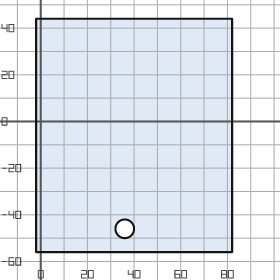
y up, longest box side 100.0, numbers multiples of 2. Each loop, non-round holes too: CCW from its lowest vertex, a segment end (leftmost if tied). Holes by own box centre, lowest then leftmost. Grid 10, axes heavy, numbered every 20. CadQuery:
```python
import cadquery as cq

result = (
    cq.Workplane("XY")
    .moveTo(-2.0, -56.0)
    .lineTo(82.0, -56.0)
    .lineTo(82.0, 44.0)
    .lineTo(-2.0, 44.0)
    .close()
    .moveTo(36.0, -46.0)
    .circle(4.0)
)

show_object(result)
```